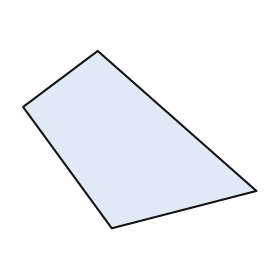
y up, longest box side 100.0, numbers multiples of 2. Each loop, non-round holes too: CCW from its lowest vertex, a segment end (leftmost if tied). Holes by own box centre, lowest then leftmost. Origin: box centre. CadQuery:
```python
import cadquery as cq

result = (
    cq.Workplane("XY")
    .moveTo(-12.0, -38.0)
    .lineTo(50.0, -22.0)
    .lineTo(-18.0, 38.0)
    .lineTo(-50.0, 14.0)
    .close()
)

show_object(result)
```